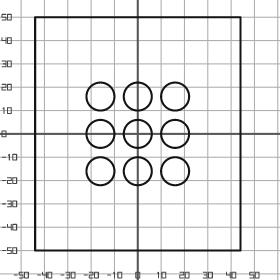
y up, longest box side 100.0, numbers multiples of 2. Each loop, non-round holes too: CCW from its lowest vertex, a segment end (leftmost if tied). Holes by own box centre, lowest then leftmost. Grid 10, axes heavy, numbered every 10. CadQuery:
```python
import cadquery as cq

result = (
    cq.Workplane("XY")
    .moveTo(-44.0, -50.0)
    .lineTo(44.0, -50.0)
    .lineTo(44.0, 50.0)
    .lineTo(-44.0, 50.0)
    .close()
    .moveTo(-16.0, -16.0)
    .circle(6.0)
    .moveTo(0.0, -16.0)
    .circle(6.0)
    .moveTo(16.0, -16.0)
    .circle(6.0)
    .moveTo(-16.0, 0.0)
    .circle(6.0)
    .moveTo(0.0, 0.0)
    .circle(6.0)
    .moveTo(16.0, 0.0)
    .circle(6.0)
    .moveTo(-16.0, 16.0)
    .circle(6.0)
    .moveTo(0.0, 16.0)
    .circle(6.0)
    .moveTo(16.0, 16.0)
    .circle(6.0)
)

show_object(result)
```